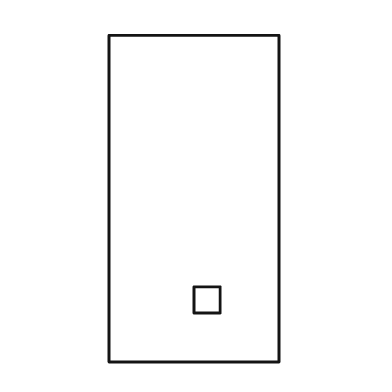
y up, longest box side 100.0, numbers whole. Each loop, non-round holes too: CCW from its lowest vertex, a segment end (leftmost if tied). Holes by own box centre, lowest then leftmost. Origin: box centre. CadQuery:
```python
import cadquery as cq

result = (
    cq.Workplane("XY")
    .moveTo(-26.0, -50.0)
    .lineTo(26.0, -50.0)
    .lineTo(26.0, 50.0)
    .lineTo(-26.0, 50.0)
    .close()
    .moveTo(0.0, -35.0)
    .lineTo(8.0, -35.0)
    .lineTo(8.0, -27.0)
    .lineTo(0.0, -27.0)
    .close()
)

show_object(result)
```